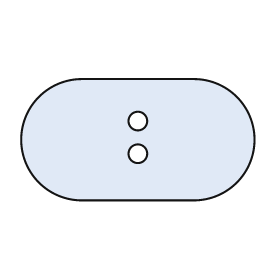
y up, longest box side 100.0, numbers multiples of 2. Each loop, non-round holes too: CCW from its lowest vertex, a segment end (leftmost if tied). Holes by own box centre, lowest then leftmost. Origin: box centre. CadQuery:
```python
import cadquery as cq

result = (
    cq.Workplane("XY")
    .moveTo(-24.0, -26.0)
    .lineTo(24.0, -26.0)
    .threePointArc((50.0, 0.0), (24.0, 26.0))
    .lineTo(-24.0, 26.0)
    .threePointArc((-50.0, 0.0), (-24.0, -26.0))
    .close()
    .moveTo(0.0, -6.0)
    .circle(4.0)
    .moveTo(0.0, 8.0)
    .circle(4.0)
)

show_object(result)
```